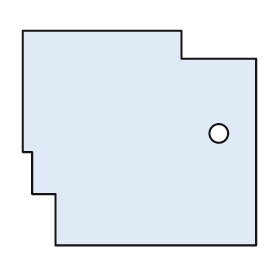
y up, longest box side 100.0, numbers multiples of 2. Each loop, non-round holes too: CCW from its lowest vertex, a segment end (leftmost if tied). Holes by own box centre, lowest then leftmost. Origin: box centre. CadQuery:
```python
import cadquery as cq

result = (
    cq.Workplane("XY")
    .moveTo(-36.0, -46.0)
    .lineTo(50.0, -46.0)
    .lineTo(50.0, 34.0)
    .lineTo(18.0, 34.0)
    .lineTo(18.0, 46.0)
    .lineTo(-50.0, 46.0)
    .lineTo(-50.0, -6.0)
    .lineTo(-46.0, -6.0)
    .lineTo(-46.0, -24.0)
    .lineTo(-36.0, -24.0)
    .close()
    .moveTo(34.0, 2.0)
    .circle(4.0)
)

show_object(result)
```